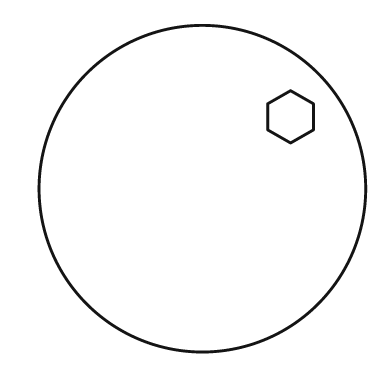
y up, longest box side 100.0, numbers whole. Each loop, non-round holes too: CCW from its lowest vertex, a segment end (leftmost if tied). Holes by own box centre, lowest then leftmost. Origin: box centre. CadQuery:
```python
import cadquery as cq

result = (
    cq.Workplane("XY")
    .moveTo(0.0, 0.0)
    .circle(50.0)
    .moveTo(27.0, 14.0)
    .lineTo(34.0, 18.0)
    .lineTo(34.0, 26.0)
    .lineTo(27.0, 30.0)
    .lineTo(20.0, 26.0)
    .lineTo(20.0, 18.0)
    .close()
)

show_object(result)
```